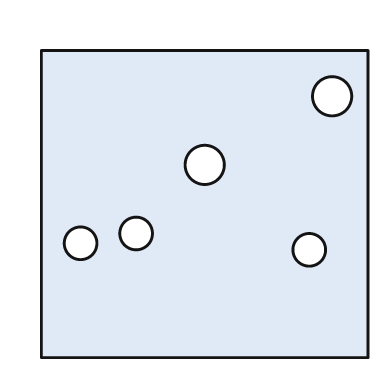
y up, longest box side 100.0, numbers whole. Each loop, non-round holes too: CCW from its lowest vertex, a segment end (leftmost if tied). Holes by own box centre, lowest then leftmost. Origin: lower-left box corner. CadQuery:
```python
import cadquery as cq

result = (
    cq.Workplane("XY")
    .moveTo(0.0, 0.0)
    .lineTo(100.0, 0.0)
    .lineTo(100.0, 94.0)
    .lineTo(0.0, 94.0)
    .close()
    .moveTo(82.0, 33.0)
    .circle(5.0)
    .moveTo(12.0, 35.0)
    .circle(5.0)
    .moveTo(29.0, 38.0)
    .circle(5.0)
    .moveTo(50.0, 59.0)
    .circle(6.0)
    .moveTo(89.0, 80.0)
    .circle(6.0)
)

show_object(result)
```